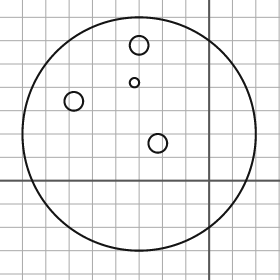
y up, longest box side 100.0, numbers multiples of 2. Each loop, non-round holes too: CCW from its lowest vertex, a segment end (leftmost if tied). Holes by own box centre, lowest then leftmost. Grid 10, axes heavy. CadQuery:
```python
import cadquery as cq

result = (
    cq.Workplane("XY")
    .moveTo(-30.0, 20.0)
    .circle(50.0)
    .moveTo(-22.0, 16.0)
    .circle(4.0)
    .moveTo(-58.0, 34.0)
    .circle(4.0)
    .moveTo(-32.0, 42.0)
    .circle(2.0)
    .moveTo(-30.0, 58.0)
    .circle(4.0)
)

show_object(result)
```